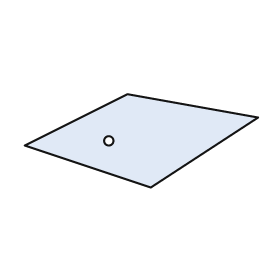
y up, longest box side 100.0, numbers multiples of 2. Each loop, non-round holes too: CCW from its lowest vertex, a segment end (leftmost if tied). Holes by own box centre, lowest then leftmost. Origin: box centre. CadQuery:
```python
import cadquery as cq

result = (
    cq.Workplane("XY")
    .moveTo(4.0, -20.0)
    .lineTo(50.0, 10.0)
    .lineTo(-6.0, 20.0)
    .lineTo(-50.0, -2.0)
    .close()
    .moveTo(-14.0, 0.0)
    .circle(2.0)
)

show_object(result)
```